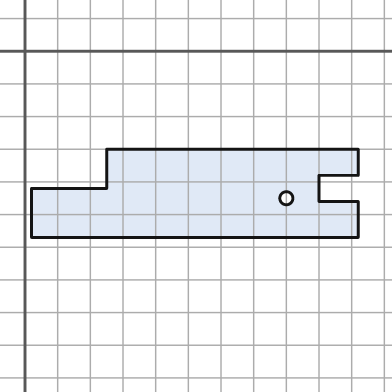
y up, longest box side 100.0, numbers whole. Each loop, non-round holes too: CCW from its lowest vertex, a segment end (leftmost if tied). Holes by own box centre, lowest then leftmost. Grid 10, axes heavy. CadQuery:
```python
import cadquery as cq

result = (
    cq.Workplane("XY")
    .moveTo(2.0, -57.0)
    .lineTo(102.0, -57.0)
    .lineTo(102.0, -46.0)
    .lineTo(90.0, -46.0)
    .lineTo(90.0, -38.0)
    .lineTo(102.0, -38.0)
    .lineTo(102.0, -30.0)
    .lineTo(25.0, -30.0)
    .lineTo(25.0, -42.0)
    .lineTo(2.0, -42.0)
    .close()
    .moveTo(80.0, -45.0)
    .circle(2.0)
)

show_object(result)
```